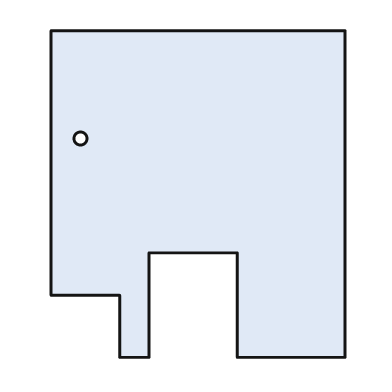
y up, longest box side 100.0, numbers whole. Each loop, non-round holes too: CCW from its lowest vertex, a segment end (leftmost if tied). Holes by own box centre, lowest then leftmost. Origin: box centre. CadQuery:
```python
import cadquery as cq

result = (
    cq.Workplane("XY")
    .moveTo(-24.0, -50.0)
    .lineTo(-15.0, -50.0)
    .lineTo(-15.0, -18.0)
    .lineTo(12.0, -18.0)
    .lineTo(12.0, -50.0)
    .lineTo(45.0, -50.0)
    .lineTo(45.0, 50.0)
    .lineTo(-45.0, 50.0)
    .lineTo(-45.0, -31.0)
    .lineTo(-24.0, -31.0)
    .close()
    .moveTo(-36.0, 17.0)
    .circle(2.0)
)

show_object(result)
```